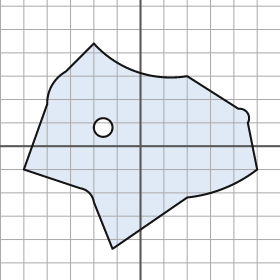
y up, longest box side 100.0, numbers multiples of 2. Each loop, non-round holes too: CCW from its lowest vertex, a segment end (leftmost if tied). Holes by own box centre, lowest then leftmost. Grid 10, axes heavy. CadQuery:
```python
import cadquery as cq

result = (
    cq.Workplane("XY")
    .moveTo(-12.0, -44.0)
    .lineTo(20.0, -22.0)
    .threePointArc((36.0, -18.0), (50.0, -10.0))
    .lineTo(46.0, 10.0)
    .threePointArc((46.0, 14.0), (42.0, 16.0))
    .lineTo(20.0, 30.0)
    .threePointArc((-2.0, 32.0), (-20.0, 44.0))
    .lineTo(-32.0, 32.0)
    .threePointArc((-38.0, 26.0), (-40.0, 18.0))
    .lineTo(-50.0, -10.0)
    .lineTo(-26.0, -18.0)
    .threePointArc((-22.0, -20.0), (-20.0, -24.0))
    .close()
    .moveTo(-16.0, 8.0)
    .circle(4.0)
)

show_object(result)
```